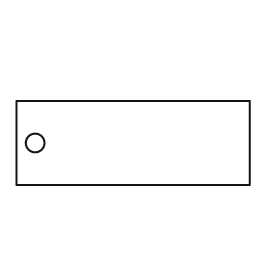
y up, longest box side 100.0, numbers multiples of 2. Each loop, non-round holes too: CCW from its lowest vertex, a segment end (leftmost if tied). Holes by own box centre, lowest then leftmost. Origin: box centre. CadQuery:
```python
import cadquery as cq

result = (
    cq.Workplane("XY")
    .moveTo(-50.0, -18.0)
    .lineTo(50.0, -18.0)
    .lineTo(50.0, 18.0)
    .lineTo(-50.0, 18.0)
    .close()
    .moveTo(-42.0, 0.0)
    .circle(4.0)
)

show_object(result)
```